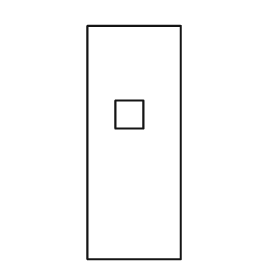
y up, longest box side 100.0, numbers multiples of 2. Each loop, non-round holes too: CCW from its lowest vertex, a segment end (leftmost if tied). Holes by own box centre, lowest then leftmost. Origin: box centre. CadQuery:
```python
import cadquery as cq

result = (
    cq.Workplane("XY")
    .moveTo(-20.0, -50.0)
    .lineTo(20.0, -50.0)
    .lineTo(20.0, 50.0)
    .lineTo(-20.0, 50.0)
    .close()
    .moveTo(-8.0, 6.0)
    .lineTo(4.0, 6.0)
    .lineTo(4.0, 18.0)
    .lineTo(-8.0, 18.0)
    .close()
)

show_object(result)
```